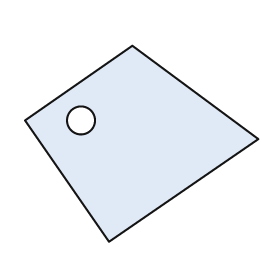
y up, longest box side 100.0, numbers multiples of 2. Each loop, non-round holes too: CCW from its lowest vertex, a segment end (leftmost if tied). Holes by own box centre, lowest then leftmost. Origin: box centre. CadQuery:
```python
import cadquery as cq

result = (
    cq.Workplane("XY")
    .moveTo(-14.0, -42.0)
    .lineTo(50.0, 2.0)
    .lineTo(-4.0, 42.0)
    .lineTo(-50.0, 10.0)
    .close()
    .moveTo(-26.0, 10.0)
    .circle(6.0)
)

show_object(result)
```